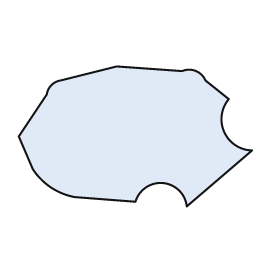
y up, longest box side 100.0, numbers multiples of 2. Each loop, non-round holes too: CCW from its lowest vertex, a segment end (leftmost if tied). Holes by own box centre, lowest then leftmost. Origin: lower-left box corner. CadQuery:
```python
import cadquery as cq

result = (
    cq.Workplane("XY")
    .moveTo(72.0, 0.0)
    .lineTo(100.0, 24.0)
    .threePointArc((88.0, 32.0), (90.0, 46.0))
    .lineTo(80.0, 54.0)
    .threePointArc((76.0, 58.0), (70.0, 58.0))
    .lineTo(42.0, 60.0)
    .lineTo(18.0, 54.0)
    .threePointArc((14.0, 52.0), (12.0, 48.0))
    .lineTo(0.0, 30.0)
    .lineTo(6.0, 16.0)
    .threePointArc((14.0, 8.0), (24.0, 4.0))
    .lineTo(50.0, 2.0)
    .threePointArc((62.0, 10.0), (72.0, 0.0))
    .close()
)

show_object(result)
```